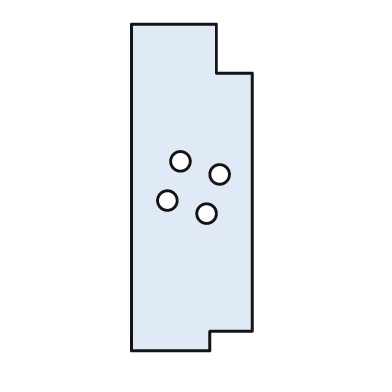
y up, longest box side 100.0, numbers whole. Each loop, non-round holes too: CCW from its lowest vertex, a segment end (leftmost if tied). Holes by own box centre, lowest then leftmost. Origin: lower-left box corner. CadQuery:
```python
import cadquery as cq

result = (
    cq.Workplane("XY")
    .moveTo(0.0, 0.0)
    .lineTo(24.0, 0.0)
    .lineTo(24.0, 6.0)
    .lineTo(37.0, 6.0)
    .lineTo(37.0, 85.0)
    .lineTo(26.0, 85.0)
    .lineTo(26.0, 100.0)
    .lineTo(0.0, 100.0)
    .close()
    .moveTo(23.0, 42.0)
    .circle(3.0)
    .moveTo(11.0, 46.0)
    .circle(3.0)
    .moveTo(27.0, 54.0)
    .circle(3.0)
    .moveTo(15.0, 58.0)
    .circle(3.0)
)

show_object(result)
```